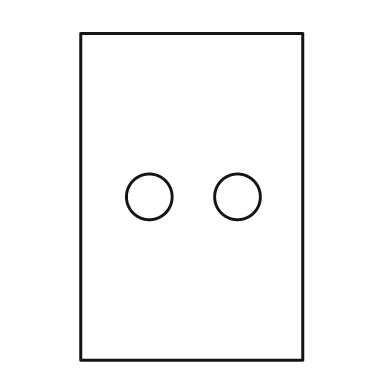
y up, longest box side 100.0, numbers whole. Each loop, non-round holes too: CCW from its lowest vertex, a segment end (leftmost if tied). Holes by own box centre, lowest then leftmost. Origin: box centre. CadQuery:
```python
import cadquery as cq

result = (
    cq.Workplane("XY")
    .moveTo(-34.0, -50.0)
    .lineTo(34.0, -50.0)
    .lineTo(34.0, 50.0)
    .lineTo(-34.0, 50.0)
    .close()
    .moveTo(-13.0, 0.0)
    .circle(7.0)
    .moveTo(14.0, 0.0)
    .circle(7.0)
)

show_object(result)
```